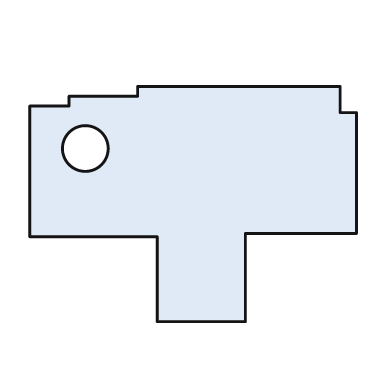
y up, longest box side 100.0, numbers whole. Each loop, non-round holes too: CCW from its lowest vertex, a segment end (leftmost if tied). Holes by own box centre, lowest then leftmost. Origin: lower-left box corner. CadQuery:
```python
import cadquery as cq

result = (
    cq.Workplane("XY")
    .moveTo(39.0, 0.0)
    .lineTo(66.0, 0.0)
    .lineTo(66.0, 27.0)
    .lineTo(100.0, 27.0)
    .lineTo(100.0, 64.0)
    .lineTo(95.0, 64.0)
    .lineTo(95.0, 72.0)
    .lineTo(33.0, 72.0)
    .lineTo(33.0, 69.0)
    .lineTo(12.0, 69.0)
    .lineTo(12.0, 66.0)
    .lineTo(0.0, 66.0)
    .lineTo(0.0, 26.0)
    .lineTo(39.0, 26.0)
    .close()
    .moveTo(17.0, 53.0)
    .circle(7.0)
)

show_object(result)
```